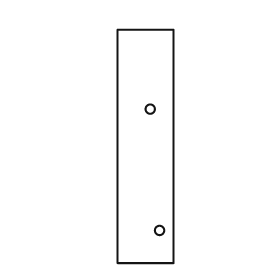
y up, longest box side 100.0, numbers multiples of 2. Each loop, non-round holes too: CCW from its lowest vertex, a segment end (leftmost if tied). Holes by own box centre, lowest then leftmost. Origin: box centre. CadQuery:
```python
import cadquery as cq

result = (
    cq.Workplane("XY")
    .moveTo(-12.0, -50.0)
    .lineTo(12.0, -50.0)
    .lineTo(12.0, 50.0)
    .lineTo(-12.0, 50.0)
    .close()
    .moveTo(6.0, -36.0)
    .circle(2.0)
    .moveTo(2.0, 16.0)
    .circle(2.0)
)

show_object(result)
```